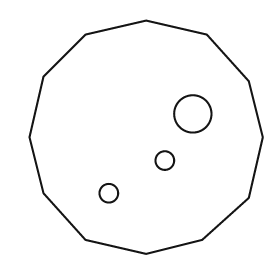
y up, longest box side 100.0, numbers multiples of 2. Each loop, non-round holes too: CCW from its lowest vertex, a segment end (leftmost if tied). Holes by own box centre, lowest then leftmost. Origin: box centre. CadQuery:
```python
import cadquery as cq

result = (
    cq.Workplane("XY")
    .moveTo(0.0, -50.0)
    .lineTo(24.0, -44.0)
    .lineTo(44.0, -26.0)
    .lineTo(50.0, 0.0)
    .lineTo(44.0, 24.0)
    .lineTo(26.0, 44.0)
    .lineTo(0.0, 50.0)
    .lineTo(-26.0, 44.0)
    .lineTo(-44.0, 26.0)
    .lineTo(-50.0, 0.0)
    .lineTo(-44.0, -24.0)
    .lineTo(-26.0, -44.0)
    .close()
    .moveTo(-16.0, -24.0)
    .circle(4.0)
    .moveTo(8.0, -10.0)
    .circle(4.0)
    .moveTo(20.0, 10.0)
    .circle(8.0)
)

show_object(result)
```